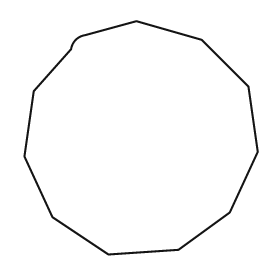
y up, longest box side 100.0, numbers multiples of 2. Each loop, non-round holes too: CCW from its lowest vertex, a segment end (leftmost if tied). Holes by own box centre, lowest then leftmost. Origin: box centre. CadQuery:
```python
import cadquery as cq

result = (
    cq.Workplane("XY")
    .moveTo(-14.0, -50.0)
    .lineTo(16.0, -48.0)
    .lineTo(38.0, -32.0)
    .lineTo(50.0, -6.0)
    .lineTo(46.0, 22.0)
    .lineTo(26.0, 42.0)
    .lineTo(-2.0, 50.0)
    .lineTo(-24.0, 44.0)
    .threePointArc((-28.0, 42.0), (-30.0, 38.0))
    .lineTo(-46.0, 20.0)
    .lineTo(-50.0, -8.0)
    .lineTo(-38.0, -34.0)
    .close()
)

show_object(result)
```